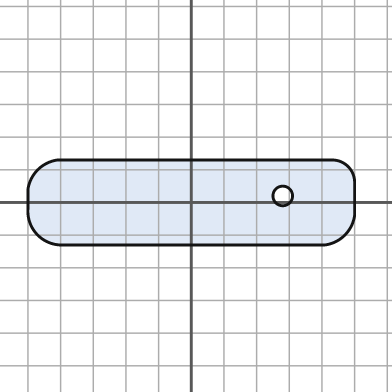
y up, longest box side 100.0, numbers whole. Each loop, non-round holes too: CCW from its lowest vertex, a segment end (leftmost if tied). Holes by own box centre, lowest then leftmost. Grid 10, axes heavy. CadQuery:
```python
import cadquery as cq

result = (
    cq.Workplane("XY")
    .moveTo(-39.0, -13.0)
    .lineTo(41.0, -13.0)
    .threePointArc((47.0, -10.0), (50.0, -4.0))
    .lineTo(50.0, 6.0)
    .threePointArc((48.0, 11.0), (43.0, 13.0))
    .lineTo(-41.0, 13.0)
    .threePointArc((-47.0, 10.0), (-50.0, 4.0))
    .lineTo(-50.0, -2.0)
    .threePointArc((-47.0, -10.0), (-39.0, -13.0))
    .close()
    .moveTo(28.0, 2.0)
    .circle(3.0)
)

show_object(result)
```